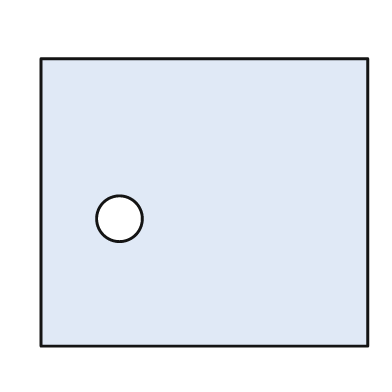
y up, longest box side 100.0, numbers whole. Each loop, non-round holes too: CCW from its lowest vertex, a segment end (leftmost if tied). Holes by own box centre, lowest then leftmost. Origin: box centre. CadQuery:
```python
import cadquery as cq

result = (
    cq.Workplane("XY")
    .moveTo(-50.0, -44.0)
    .lineTo(50.0, -44.0)
    .lineTo(50.0, 44.0)
    .lineTo(-50.0, 44.0)
    .close()
    .moveTo(-26.0, -5.0)
    .circle(7.0)
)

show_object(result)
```